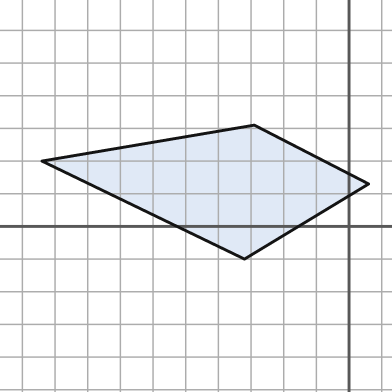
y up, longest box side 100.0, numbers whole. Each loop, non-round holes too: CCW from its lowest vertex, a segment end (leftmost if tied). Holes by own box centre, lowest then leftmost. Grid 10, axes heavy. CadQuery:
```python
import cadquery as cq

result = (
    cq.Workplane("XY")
    .moveTo(-32.0, -10.0)
    .lineTo(6.0, 13.0)
    .lineTo(-29.0, 31.0)
    .lineTo(-94.0, 20.0)
    .close()
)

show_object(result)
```